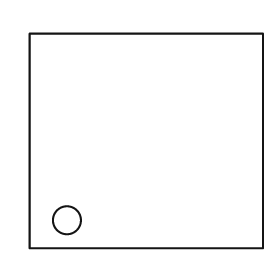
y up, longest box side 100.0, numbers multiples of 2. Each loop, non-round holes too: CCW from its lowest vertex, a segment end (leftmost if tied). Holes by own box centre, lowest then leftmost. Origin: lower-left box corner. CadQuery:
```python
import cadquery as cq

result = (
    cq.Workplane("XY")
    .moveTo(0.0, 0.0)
    .lineTo(100.0, 0.0)
    .lineTo(100.0, 92.0)
    .lineTo(0.0, 92.0)
    .close()
    .moveTo(16.0, 12.0)
    .circle(6.0)
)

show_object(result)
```